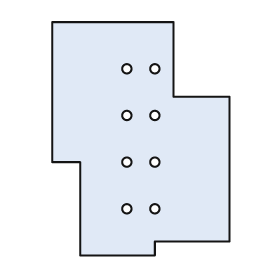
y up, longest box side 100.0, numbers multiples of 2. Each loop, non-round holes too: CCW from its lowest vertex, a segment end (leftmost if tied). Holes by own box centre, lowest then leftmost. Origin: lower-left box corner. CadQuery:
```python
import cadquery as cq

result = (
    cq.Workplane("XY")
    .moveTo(12.0, 0.0)
    .lineTo(44.0, 0.0)
    .lineTo(44.0, 6.0)
    .lineTo(76.0, 6.0)
    .lineTo(76.0, 68.0)
    .lineTo(52.0, 68.0)
    .lineTo(52.0, 100.0)
    .lineTo(0.0, 100.0)
    .lineTo(0.0, 40.0)
    .lineTo(12.0, 40.0)
    .close()
    .moveTo(32.0, 20.0)
    .circle(2.0)
    .moveTo(44.0, 20.0)
    .circle(2.0)
    .moveTo(32.0, 40.0)
    .circle(2.0)
    .moveTo(44.0, 40.0)
    .circle(2.0)
    .moveTo(32.0, 60.0)
    .circle(2.0)
    .moveTo(44.0, 60.0)
    .circle(2.0)
    .moveTo(32.0, 80.0)
    .circle(2.0)
    .moveTo(44.0, 80.0)
    .circle(2.0)
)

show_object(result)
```